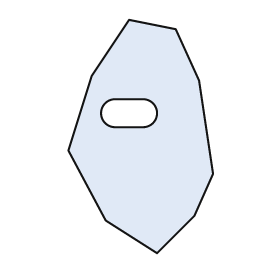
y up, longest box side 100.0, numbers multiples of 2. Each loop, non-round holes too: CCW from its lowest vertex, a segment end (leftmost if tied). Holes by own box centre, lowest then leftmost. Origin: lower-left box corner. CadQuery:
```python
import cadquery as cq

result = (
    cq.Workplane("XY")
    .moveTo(38.0, 0.0)
    .lineTo(54.0, 16.0)
    .lineTo(62.0, 34.0)
    .lineTo(56.0, 74.0)
    .lineTo(46.0, 96.0)
    .lineTo(26.0, 100.0)
    .lineTo(10.0, 76.0)
    .lineTo(0.0, 44.0)
    .lineTo(16.0, 14.0)
    .close()
    .moveTo(20.0, 54.0)
    .lineTo(32.0, 54.0)
    .threePointArc((38.0, 60.0), (32.0, 66.0))
    .lineTo(20.0, 66.0)
    .threePointArc((14.0, 60.0), (20.0, 54.0))
    .close()
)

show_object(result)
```